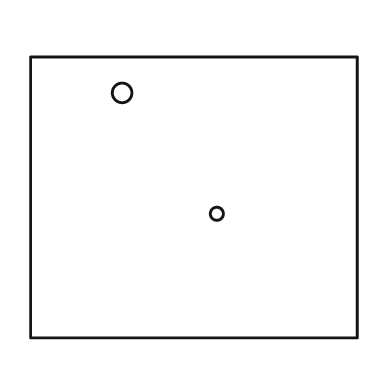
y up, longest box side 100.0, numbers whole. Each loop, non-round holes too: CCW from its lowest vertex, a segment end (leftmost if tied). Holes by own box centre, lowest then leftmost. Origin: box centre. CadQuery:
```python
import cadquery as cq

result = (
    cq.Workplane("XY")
    .moveTo(-50.0, -43.0)
    .lineTo(50.0, -43.0)
    .lineTo(50.0, 43.0)
    .lineTo(-50.0, 43.0)
    .close()
    .moveTo(7.0, -5.0)
    .circle(2.0)
    .moveTo(-22.0, 32.0)
    .circle(3.0)
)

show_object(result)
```